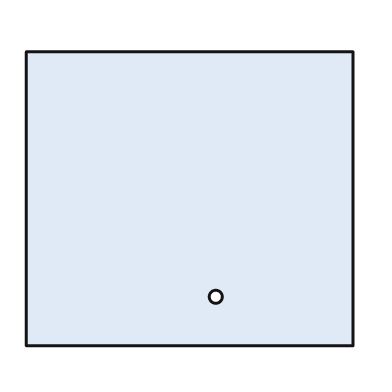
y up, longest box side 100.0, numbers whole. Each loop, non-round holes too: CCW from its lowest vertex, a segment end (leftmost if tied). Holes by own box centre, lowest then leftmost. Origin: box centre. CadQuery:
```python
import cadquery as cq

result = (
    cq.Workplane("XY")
    .moveTo(-50.0, -45.0)
    .lineTo(50.0, -45.0)
    .lineTo(50.0, 45.0)
    .lineTo(-50.0, 45.0)
    .close()
    .moveTo(8.0, -30.0)
    .circle(2.0)
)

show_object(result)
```